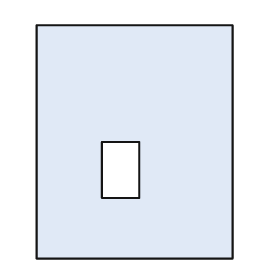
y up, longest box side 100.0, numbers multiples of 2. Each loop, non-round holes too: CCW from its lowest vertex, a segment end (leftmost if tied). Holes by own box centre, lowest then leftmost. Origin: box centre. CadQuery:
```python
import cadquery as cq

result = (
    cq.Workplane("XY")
    .moveTo(-42.0, -50.0)
    .lineTo(42.0, -50.0)
    .lineTo(42.0, 50.0)
    .lineTo(-42.0, 50.0)
    .close()
    .moveTo(-14.0, -24.0)
    .lineTo(2.0, -24.0)
    .lineTo(2.0, 0.0)
    .lineTo(-14.0, 0.0)
    .close()
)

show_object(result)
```